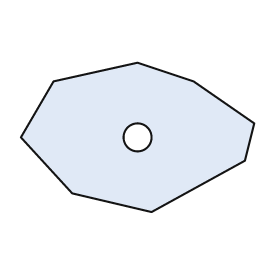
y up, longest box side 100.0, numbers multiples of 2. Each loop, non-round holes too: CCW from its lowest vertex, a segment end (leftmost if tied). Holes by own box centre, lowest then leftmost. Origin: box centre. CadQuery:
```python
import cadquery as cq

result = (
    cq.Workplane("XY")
    .moveTo(6.0, -32.0)
    .lineTo(46.0, -10.0)
    .lineTo(50.0, 6.0)
    .lineTo(24.0, 24.0)
    .lineTo(0.0, 32.0)
    .lineTo(-36.0, 24.0)
    .lineTo(-50.0, 0.0)
    .lineTo(-28.0, -24.0)
    .close()
    .moveTo(0.0, 0.0)
    .circle(6.0)
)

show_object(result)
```